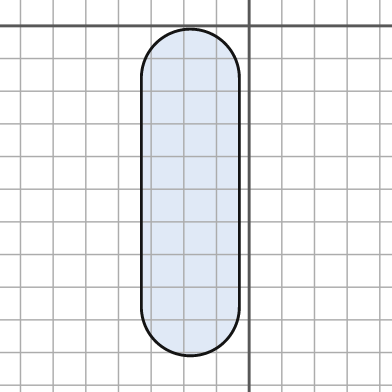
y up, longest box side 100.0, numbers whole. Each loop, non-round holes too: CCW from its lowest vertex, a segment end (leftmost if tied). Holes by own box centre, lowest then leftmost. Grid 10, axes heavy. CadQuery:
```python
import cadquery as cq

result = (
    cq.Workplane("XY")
    .moveTo(-33.0, -86.0)
    .threePointArc((-18.0, -101.0), (-3.0, -86.0))
    .lineTo(-3.0, -16.0)
    .threePointArc((-18.0, -1.0), (-33.0, -16.0))
    .close()
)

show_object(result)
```